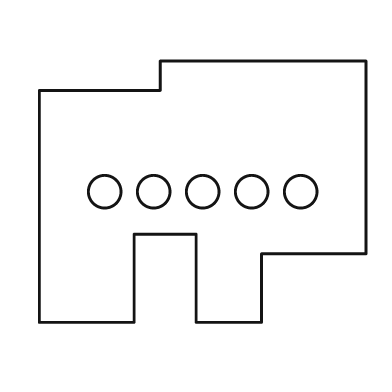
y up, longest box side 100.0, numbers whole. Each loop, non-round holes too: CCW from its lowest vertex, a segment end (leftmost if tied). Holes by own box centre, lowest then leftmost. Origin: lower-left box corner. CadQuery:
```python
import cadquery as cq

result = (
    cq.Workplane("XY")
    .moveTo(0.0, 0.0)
    .lineTo(29.0, 0.0)
    .lineTo(29.0, 27.0)
    .lineTo(48.0, 27.0)
    .lineTo(48.0, 0.0)
    .lineTo(68.0, 0.0)
    .lineTo(68.0, 21.0)
    .lineTo(100.0, 21.0)
    .lineTo(100.0, 80.0)
    .lineTo(37.0, 80.0)
    .lineTo(37.0, 71.0)
    .lineTo(0.0, 71.0)
    .close()
    .moveTo(20.0, 40.0)
    .circle(5.0)
    .moveTo(35.0, 40.0)
    .circle(5.0)
    .moveTo(50.0, 40.0)
    .circle(5.0)
    .moveTo(65.0, 40.0)
    .circle(5.0)
    .moveTo(80.0, 40.0)
    .circle(5.0)
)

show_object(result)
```